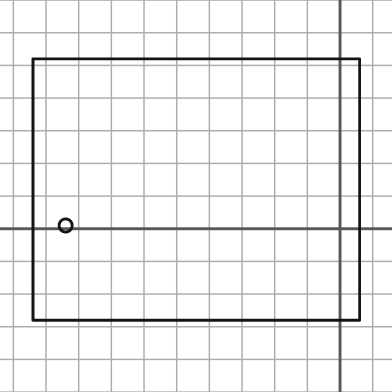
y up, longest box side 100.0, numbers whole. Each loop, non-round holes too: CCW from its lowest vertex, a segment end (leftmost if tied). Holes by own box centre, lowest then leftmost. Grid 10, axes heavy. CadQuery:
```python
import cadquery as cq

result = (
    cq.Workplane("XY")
    .moveTo(-94.0, -28.0)
    .lineTo(6.0, -28.0)
    .lineTo(6.0, 52.0)
    .lineTo(-94.0, 52.0)
    .close()
    .moveTo(-84.0, 1.0)
    .circle(2.0)
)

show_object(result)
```